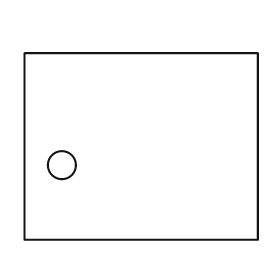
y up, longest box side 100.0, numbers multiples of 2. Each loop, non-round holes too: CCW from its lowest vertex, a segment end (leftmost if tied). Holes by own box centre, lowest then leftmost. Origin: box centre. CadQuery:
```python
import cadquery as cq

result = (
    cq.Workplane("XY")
    .moveTo(-50.0, -40.0)
    .lineTo(50.0, -40.0)
    .lineTo(50.0, 40.0)
    .lineTo(-50.0, 40.0)
    .close()
    .moveTo(-34.0, -8.0)
    .circle(6.0)
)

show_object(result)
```